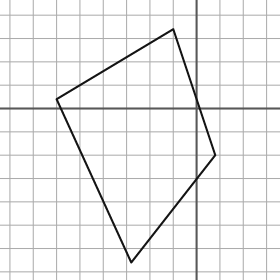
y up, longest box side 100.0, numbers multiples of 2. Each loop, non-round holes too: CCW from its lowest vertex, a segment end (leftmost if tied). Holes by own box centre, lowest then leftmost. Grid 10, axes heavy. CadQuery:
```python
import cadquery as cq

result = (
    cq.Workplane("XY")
    .moveTo(-28.0, -66.0)
    .lineTo(8.0, -20.0)
    .lineTo(-10.0, 34.0)
    .lineTo(-60.0, 4.0)
    .close()
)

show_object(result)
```